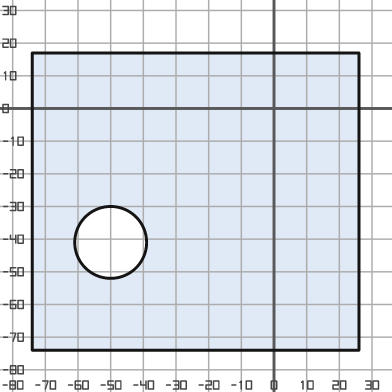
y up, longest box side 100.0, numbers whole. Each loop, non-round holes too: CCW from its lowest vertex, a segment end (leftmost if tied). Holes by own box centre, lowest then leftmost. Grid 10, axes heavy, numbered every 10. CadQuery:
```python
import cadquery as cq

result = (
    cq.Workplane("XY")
    .moveTo(-74.0, -74.0)
    .lineTo(26.0, -74.0)
    .lineTo(26.0, 17.0)
    .lineTo(-74.0, 17.0)
    .close()
    .moveTo(-50.0, -41.0)
    .circle(11.0)
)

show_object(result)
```